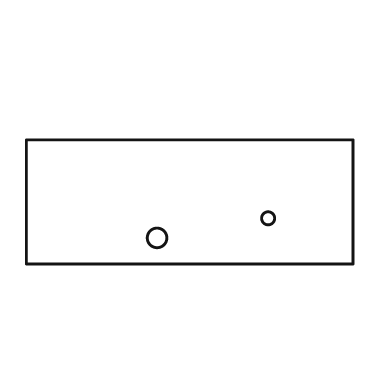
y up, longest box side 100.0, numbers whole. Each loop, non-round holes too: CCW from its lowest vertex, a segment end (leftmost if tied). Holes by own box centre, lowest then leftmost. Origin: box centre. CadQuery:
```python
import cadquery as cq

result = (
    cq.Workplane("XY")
    .moveTo(-50.0, -19.0)
    .lineTo(50.0, -19.0)
    .lineTo(50.0, 19.0)
    .lineTo(-50.0, 19.0)
    .close()
    .moveTo(-10.0, -11.0)
    .circle(3.0)
    .moveTo(24.0, -5.0)
    .circle(2.0)
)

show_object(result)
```